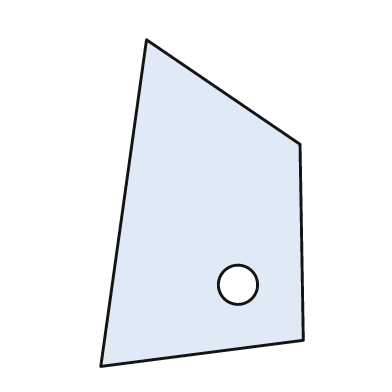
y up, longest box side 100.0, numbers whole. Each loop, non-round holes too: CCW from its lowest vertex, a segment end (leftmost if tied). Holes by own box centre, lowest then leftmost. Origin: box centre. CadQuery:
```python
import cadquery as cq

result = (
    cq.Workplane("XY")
    .moveTo(-31.0, -50.0)
    .lineTo(31.0, -42.0)
    .lineTo(30.0, 18.0)
    .lineTo(-17.0, 50.0)
    .close()
    .moveTo(11.0, -25.0)
    .circle(6.0)
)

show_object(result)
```